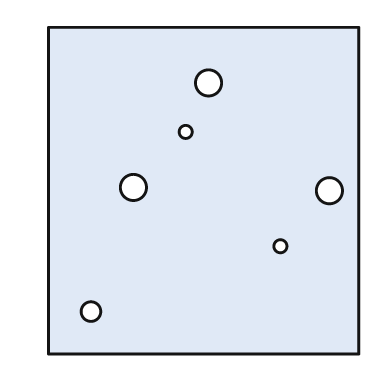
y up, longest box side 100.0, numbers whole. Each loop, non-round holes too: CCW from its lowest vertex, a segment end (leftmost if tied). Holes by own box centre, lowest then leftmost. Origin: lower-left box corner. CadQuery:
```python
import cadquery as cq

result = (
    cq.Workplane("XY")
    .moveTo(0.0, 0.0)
    .lineTo(95.0, 0.0)
    .lineTo(95.0, 100.0)
    .lineTo(0.0, 100.0)
    .close()
    .moveTo(13.0, 13.0)
    .circle(3.0)
    .moveTo(71.0, 33.0)
    .circle(2.0)
    .moveTo(86.0, 50.0)
    .circle(4.0)
    .moveTo(26.0, 51.0)
    .circle(4.0)
    .moveTo(42.0, 68.0)
    .circle(2.0)
    .moveTo(49.0, 83.0)
    .circle(4.0)
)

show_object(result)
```